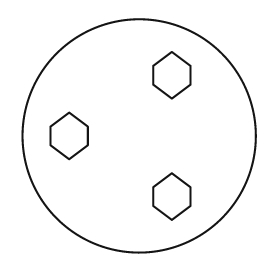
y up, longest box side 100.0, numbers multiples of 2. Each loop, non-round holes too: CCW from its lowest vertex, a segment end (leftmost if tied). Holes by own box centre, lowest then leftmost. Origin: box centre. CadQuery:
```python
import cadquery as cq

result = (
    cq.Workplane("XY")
    .moveTo(0.0, 0.0)
    .circle(50.0)
    .moveTo(14.0, -36.0)
    .lineTo(22.0, -30.0)
    .lineTo(22.0, -22.0)
    .lineTo(14.0, -16.0)
    .lineTo(6.0, -22.0)
    .lineTo(6.0, -30.0)
    .close()
    .moveTo(-30.0, -10.0)
    .lineTo(-22.0, -4.0)
    .lineTo(-22.0, 4.0)
    .lineTo(-30.0, 10.0)
    .lineTo(-38.0, 4.0)
    .lineTo(-38.0, -4.0)
    .close()
    .moveTo(14.0, 16.0)
    .lineTo(22.0, 22.0)
    .lineTo(22.0, 30.0)
    .lineTo(14.0, 36.0)
    .lineTo(6.0, 30.0)
    .lineTo(6.0, 22.0)
    .close()
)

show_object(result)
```